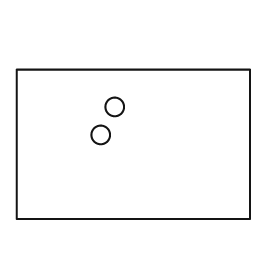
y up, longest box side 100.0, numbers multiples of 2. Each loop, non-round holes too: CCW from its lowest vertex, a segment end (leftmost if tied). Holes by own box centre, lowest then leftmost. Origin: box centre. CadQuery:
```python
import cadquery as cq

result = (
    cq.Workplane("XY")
    .moveTo(-50.0, -32.0)
    .lineTo(50.0, -32.0)
    .lineTo(50.0, 32.0)
    .lineTo(-50.0, 32.0)
    .close()
    .moveTo(-14.0, 4.0)
    .circle(4.0)
    .moveTo(-8.0, 16.0)
    .circle(4.0)
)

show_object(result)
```